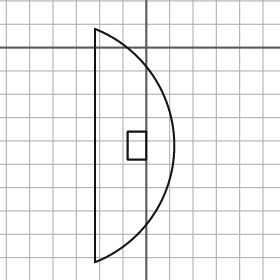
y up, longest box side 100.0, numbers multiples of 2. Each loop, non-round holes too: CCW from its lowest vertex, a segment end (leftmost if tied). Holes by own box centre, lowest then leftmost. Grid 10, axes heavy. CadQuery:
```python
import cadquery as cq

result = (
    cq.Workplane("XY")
    .moveTo(-22.0, -92.0)
    .threePointArc((12.0, -42.0), (-22.0, 8.0))
    .close()
    .moveTo(-8.0, -48.0)
    .lineTo(0.0, -48.0)
    .lineTo(0.0, -36.0)
    .lineTo(-8.0, -36.0)
    .close()
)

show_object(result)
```